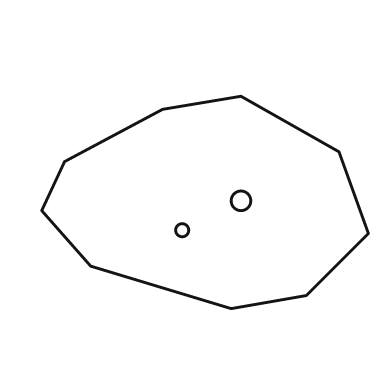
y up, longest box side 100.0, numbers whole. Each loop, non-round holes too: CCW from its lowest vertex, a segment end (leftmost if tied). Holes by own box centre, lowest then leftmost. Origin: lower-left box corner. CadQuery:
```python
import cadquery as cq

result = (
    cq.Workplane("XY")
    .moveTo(58.0, 0.0)
    .lineTo(81.0, 4.0)
    .lineTo(100.0, 23.0)
    .lineTo(91.0, 48.0)
    .lineTo(61.0, 65.0)
    .lineTo(37.0, 61.0)
    .lineTo(7.0, 45.0)
    .lineTo(0.0, 30.0)
    .lineTo(15.0, 13.0)
    .close()
    .moveTo(43.0, 24.0)
    .circle(2.0)
    .moveTo(61.0, 33.0)
    .circle(3.0)
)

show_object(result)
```